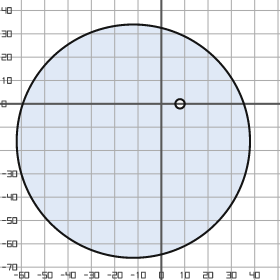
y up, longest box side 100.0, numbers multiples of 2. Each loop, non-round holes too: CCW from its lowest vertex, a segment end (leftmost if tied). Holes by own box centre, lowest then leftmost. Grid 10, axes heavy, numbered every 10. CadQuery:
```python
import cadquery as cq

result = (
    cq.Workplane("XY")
    .moveTo(-12.0, -16.0)
    .circle(50.0)
    .moveTo(8.0, 0.0)
    .circle(2.0)
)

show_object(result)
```